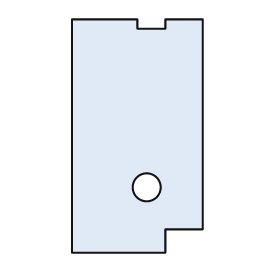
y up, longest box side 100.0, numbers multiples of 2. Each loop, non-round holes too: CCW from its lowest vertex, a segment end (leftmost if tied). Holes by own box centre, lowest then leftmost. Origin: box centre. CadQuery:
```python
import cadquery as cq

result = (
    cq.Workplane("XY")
    .moveTo(-28.0, -50.0)
    .lineTo(12.0, -50.0)
    .lineTo(12.0, -40.0)
    .lineTo(28.0, -40.0)
    .lineTo(28.0, 50.0)
    .lineTo(12.0, 50.0)
    .lineTo(12.0, 46.0)
    .lineTo(0.0, 46.0)
    .lineTo(0.0, 50.0)
    .lineTo(-28.0, 50.0)
    .close()
    .moveTo(4.0, -22.0)
    .circle(6.0)
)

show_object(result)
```